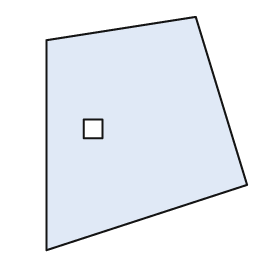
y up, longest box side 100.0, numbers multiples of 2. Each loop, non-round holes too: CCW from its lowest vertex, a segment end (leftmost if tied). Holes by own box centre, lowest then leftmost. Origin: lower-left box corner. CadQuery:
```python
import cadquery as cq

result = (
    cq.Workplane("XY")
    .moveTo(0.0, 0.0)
    .lineTo(86.0, 28.0)
    .lineTo(64.0, 100.0)
    .lineTo(0.0, 90.0)
    .close()
    .moveTo(16.0, 48.0)
    .lineTo(24.0, 48.0)
    .lineTo(24.0, 56.0)
    .lineTo(16.0, 56.0)
    .close()
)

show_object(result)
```